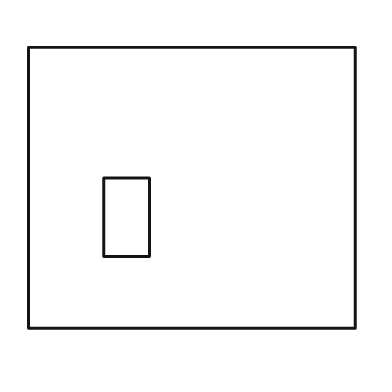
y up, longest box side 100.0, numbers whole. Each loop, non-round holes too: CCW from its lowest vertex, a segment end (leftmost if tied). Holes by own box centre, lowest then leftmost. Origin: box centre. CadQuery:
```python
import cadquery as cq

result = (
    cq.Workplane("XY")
    .moveTo(-50.0, -43.0)
    .lineTo(50.0, -43.0)
    .lineTo(50.0, 43.0)
    .lineTo(-50.0, 43.0)
    .close()
    .moveTo(-27.0, -21.0)
    .lineTo(-13.0, -21.0)
    .lineTo(-13.0, 3.0)
    .lineTo(-27.0, 3.0)
    .close()
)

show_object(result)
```